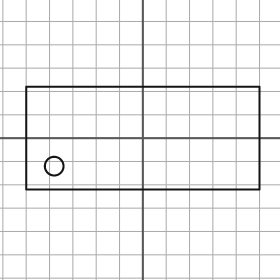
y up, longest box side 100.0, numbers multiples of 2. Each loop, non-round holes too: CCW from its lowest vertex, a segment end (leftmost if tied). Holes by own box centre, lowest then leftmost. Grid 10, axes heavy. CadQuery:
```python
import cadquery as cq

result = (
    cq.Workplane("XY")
    .moveTo(-50.0, -22.0)
    .lineTo(50.0, -22.0)
    .lineTo(50.0, 22.0)
    .lineTo(-50.0, 22.0)
    .close()
    .moveTo(-38.0, -12.0)
    .circle(4.0)
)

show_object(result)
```